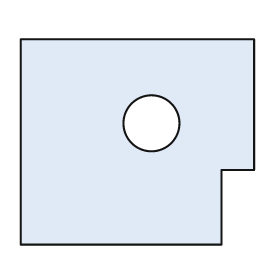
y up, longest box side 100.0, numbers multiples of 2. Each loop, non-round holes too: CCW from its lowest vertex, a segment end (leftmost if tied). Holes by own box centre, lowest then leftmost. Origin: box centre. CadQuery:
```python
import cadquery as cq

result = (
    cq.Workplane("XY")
    .moveTo(-50.0, -44.0)
    .lineTo(36.0, -44.0)
    .lineTo(36.0, -12.0)
    .lineTo(50.0, -12.0)
    .lineTo(50.0, 44.0)
    .lineTo(-50.0, 44.0)
    .close()
    .moveTo(6.0, 8.0)
    .circle(12.0)
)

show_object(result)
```